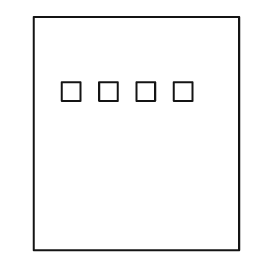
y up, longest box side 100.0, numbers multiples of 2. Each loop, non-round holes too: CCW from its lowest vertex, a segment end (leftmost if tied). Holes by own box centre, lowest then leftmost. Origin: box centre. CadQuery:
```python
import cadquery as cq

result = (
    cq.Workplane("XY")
    .moveTo(-44.0, -50.0)
    .lineTo(44.0, -50.0)
    .lineTo(44.0, 50.0)
    .lineTo(-44.0, 50.0)
    .close()
    .moveTo(-32.0, 14.0)
    .lineTo(-24.0, 14.0)
    .lineTo(-24.0, 22.0)
    .lineTo(-32.0, 22.0)
    .close()
    .moveTo(-16.0, 14.0)
    .lineTo(-8.0, 14.0)
    .lineTo(-8.0, 22.0)
    .lineTo(-16.0, 22.0)
    .close()
    .moveTo(0.0, 14.0)
    .lineTo(8.0, 14.0)
    .lineTo(8.0, 22.0)
    .lineTo(0.0, 22.0)
    .close()
    .moveTo(16.0, 14.0)
    .lineTo(24.0, 14.0)
    .lineTo(24.0, 22.0)
    .lineTo(16.0, 22.0)
    .close()
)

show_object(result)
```